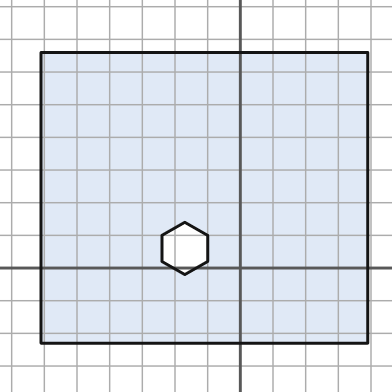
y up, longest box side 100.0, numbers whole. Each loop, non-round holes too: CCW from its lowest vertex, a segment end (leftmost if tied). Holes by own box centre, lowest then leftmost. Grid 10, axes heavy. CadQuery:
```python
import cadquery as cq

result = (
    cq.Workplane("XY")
    .moveTo(-61.0, -23.0)
    .lineTo(39.0, -23.0)
    .lineTo(39.0, 66.0)
    .lineTo(-61.0, 66.0)
    .close()
    .moveTo(-17.0, -2.0)
    .lineTo(-10.0, 2.0)
    .lineTo(-10.0, 10.0)
    .lineTo(-17.0, 14.0)
    .lineTo(-24.0, 10.0)
    .lineTo(-24.0, 2.0)
    .close()
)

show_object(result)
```